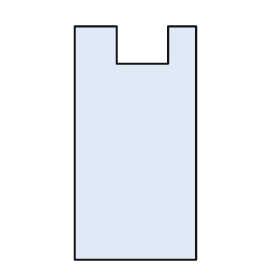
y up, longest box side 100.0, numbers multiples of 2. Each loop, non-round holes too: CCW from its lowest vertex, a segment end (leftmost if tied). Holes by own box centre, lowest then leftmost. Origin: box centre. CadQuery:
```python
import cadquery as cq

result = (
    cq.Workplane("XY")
    .moveTo(-26.0, -50.0)
    .lineTo(26.0, -50.0)
    .lineTo(26.0, 50.0)
    .lineTo(14.0, 50.0)
    .lineTo(14.0, 34.0)
    .lineTo(-8.0, 34.0)
    .lineTo(-8.0, 50.0)
    .lineTo(-26.0, 50.0)
    .close()
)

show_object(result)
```